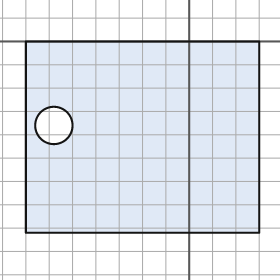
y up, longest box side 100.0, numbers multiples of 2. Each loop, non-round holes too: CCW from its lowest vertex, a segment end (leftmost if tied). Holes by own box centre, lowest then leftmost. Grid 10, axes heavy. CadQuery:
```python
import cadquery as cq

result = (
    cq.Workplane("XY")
    .moveTo(-70.0, -82.0)
    .lineTo(30.0, -82.0)
    .lineTo(30.0, 0.0)
    .lineTo(-70.0, 0.0)
    .close()
    .moveTo(-58.0, -36.0)
    .circle(8.0)
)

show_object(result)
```